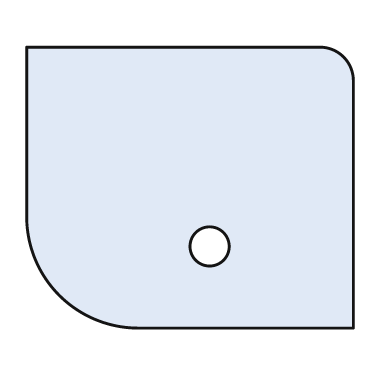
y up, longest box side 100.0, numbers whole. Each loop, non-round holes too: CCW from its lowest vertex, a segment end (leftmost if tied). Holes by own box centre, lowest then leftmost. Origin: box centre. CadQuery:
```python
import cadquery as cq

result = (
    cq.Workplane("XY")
    .moveTo(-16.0, -43.0)
    .lineTo(50.0, -43.0)
    .lineTo(50.0, 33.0)
    .threePointArc((47.0, 40.0), (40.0, 43.0))
    .lineTo(-50.0, 43.0)
    .lineTo(-50.0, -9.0)
    .threePointArc((-40.0, -33.0), (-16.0, -43.0))
    .close()
    .moveTo(6.0, -18.0)
    .circle(6.0)
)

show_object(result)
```